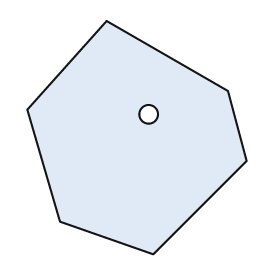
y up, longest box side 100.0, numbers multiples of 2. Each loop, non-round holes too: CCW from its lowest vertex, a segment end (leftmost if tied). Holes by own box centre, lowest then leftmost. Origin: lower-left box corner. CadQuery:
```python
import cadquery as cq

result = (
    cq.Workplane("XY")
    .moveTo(54.0, 0.0)
    .lineTo(94.0, 40.0)
    .lineTo(86.0, 70.0)
    .lineTo(34.0, 100.0)
    .lineTo(0.0, 62.0)
    .lineTo(14.0, 14.0)
    .close()
    .moveTo(52.0, 60.0)
    .circle(4.0)
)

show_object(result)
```